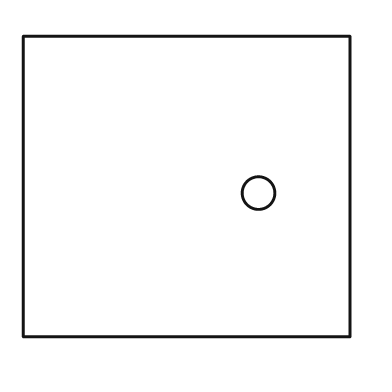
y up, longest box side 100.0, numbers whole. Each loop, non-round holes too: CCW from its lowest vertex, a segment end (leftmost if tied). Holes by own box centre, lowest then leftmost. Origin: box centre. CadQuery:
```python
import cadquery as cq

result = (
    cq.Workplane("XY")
    .moveTo(-50.0, -46.0)
    .lineTo(50.0, -46.0)
    .lineTo(50.0, 46.0)
    .lineTo(-50.0, 46.0)
    .close()
    .moveTo(22.0, -2.0)
    .circle(5.0)
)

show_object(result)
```